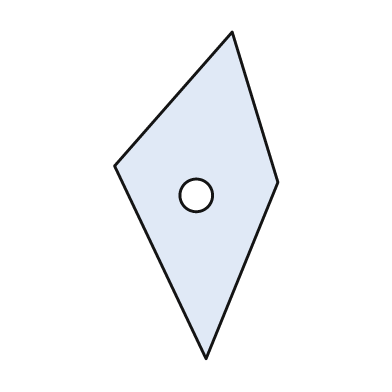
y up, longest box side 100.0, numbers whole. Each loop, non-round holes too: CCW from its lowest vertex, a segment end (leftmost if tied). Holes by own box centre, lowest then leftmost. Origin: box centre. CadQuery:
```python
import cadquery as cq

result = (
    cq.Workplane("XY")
    .moveTo(3.0, -50.0)
    .lineTo(25.0, 4.0)
    .lineTo(11.0, 50.0)
    .lineTo(-25.0, 9.0)
    .close()
    .moveTo(0.0, 0.0)
    .circle(5.0)
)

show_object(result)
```